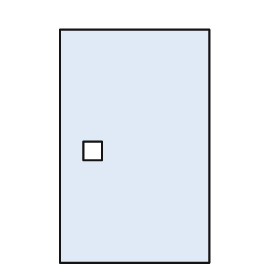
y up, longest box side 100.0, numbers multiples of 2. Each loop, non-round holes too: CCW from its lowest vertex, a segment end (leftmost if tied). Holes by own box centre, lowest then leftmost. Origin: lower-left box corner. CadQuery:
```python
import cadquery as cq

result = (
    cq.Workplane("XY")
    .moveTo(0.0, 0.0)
    .lineTo(64.0, 0.0)
    .lineTo(64.0, 100.0)
    .lineTo(0.0, 100.0)
    .close()
    .moveTo(10.0, 44.0)
    .lineTo(18.0, 44.0)
    .lineTo(18.0, 52.0)
    .lineTo(10.0, 52.0)
    .close()
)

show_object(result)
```